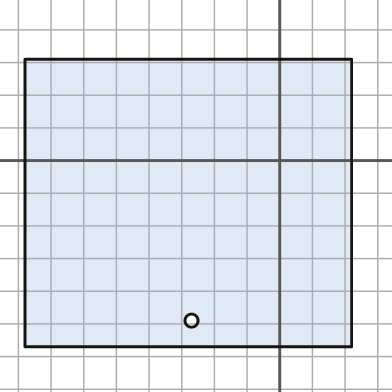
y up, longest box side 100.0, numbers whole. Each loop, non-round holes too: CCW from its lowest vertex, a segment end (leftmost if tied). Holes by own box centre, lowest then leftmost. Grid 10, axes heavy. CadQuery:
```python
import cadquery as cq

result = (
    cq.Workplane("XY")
    .moveTo(-78.0, -57.0)
    .lineTo(22.0, -57.0)
    .lineTo(22.0, 31.0)
    .lineTo(-78.0, 31.0)
    .close()
    .moveTo(-27.0, -49.0)
    .circle(2.0)
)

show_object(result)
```